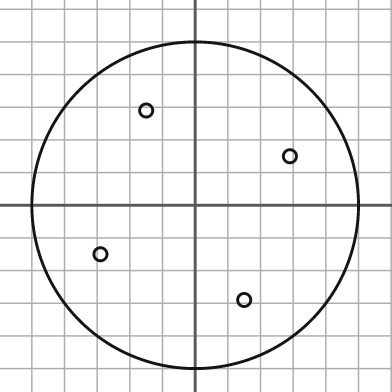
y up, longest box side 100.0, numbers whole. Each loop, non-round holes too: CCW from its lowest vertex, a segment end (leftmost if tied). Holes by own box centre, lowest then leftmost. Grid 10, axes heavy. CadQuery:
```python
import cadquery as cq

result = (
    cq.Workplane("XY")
    .moveTo(0.0, 0.0)
    .circle(50.0)
    .moveTo(15.0, -29.0)
    .circle(2.0)
    .moveTo(-29.0, -15.0)
    .circle(2.0)
    .moveTo(29.0, 15.0)
    .circle(2.0)
    .moveTo(-15.0, 29.0)
    .circle(2.0)
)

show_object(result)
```